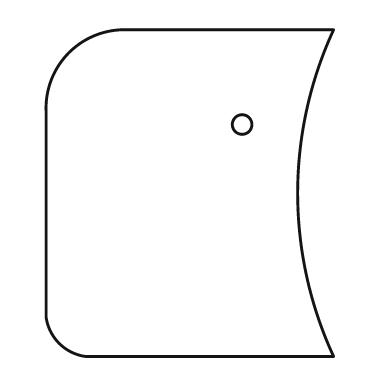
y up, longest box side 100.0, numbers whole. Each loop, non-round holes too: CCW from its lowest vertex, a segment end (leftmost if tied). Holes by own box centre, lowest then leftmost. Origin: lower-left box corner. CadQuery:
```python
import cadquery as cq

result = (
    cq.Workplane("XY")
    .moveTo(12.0, 0.0)
    .lineTo(88.0, 0.0)
    .threePointArc((77.0, 50.0), (88.0, 100.0))
    .lineTo(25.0, 100.0)
    .threePointArc((7.0, 93.0), (0.0, 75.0))
    .lineTo(0.0, 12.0)
    .threePointArc((4.0, 4.0), (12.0, 0.0))
    .close()
    .moveTo(60.0, 71.0)
    .circle(3.0)
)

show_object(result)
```